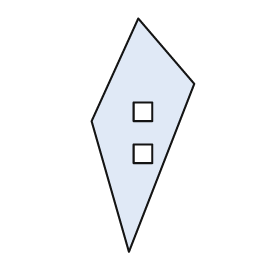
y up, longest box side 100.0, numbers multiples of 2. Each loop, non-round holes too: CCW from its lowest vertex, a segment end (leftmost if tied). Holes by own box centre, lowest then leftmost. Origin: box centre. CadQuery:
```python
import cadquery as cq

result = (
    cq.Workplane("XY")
    .moveTo(-6.0, -50.0)
    .lineTo(22.0, 22.0)
    .lineTo(-2.0, 50.0)
    .lineTo(-22.0, 6.0)
    .close()
    .moveTo(-4.0, -12.0)
    .lineTo(4.0, -12.0)
    .lineTo(4.0, -4.0)
    .lineTo(-4.0, -4.0)
    .close()
    .moveTo(-4.0, 6.0)
    .lineTo(4.0, 6.0)
    .lineTo(4.0, 14.0)
    .lineTo(-4.0, 14.0)
    .close()
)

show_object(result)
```